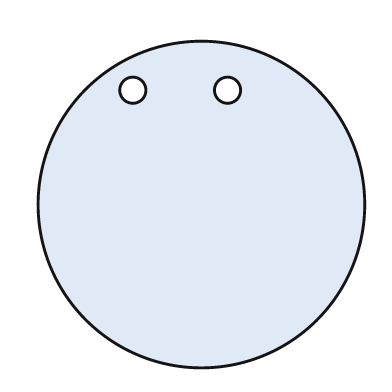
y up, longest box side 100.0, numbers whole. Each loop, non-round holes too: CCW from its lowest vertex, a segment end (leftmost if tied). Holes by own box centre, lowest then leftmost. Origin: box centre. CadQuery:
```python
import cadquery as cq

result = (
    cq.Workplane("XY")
    .moveTo(0.0, 0.0)
    .circle(50.0)
    .moveTo(-21.0, 35.0)
    .circle(4.0)
    .moveTo(8.0, 35.0)
    .circle(4.0)
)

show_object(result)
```